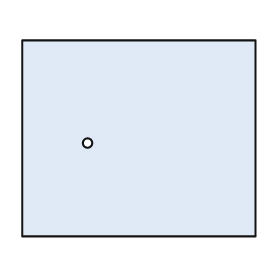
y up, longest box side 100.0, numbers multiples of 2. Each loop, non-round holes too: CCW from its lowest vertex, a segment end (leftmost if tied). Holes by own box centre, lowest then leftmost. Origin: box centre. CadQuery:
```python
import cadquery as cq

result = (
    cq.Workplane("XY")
    .moveTo(-50.0, -42.0)
    .lineTo(50.0, -42.0)
    .lineTo(50.0, 42.0)
    .lineTo(-50.0, 42.0)
    .close()
    .moveTo(-22.0, -2.0)
    .circle(2.0)
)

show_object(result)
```